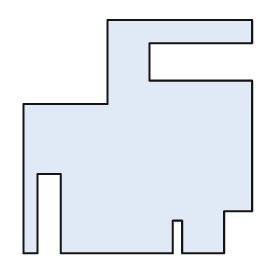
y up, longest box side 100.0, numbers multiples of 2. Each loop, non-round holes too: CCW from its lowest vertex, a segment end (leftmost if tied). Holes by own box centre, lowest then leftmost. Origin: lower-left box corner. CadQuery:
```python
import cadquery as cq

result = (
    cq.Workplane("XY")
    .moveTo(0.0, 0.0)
    .lineTo(6.0, 0.0)
    .lineTo(6.0, 34.0)
    .lineTo(16.0, 34.0)
    .lineTo(16.0, 0.0)
    .lineTo(64.0, 0.0)
    .lineTo(64.0, 14.0)
    .lineTo(68.0, 14.0)
    .lineTo(68.0, 0.0)
    .lineTo(86.0, 0.0)
    .lineTo(86.0, 18.0)
    .lineTo(98.0, 18.0)
    .lineTo(98.0, 74.0)
    .lineTo(54.0, 74.0)
    .lineTo(54.0, 90.0)
    .lineTo(98.0, 90.0)
    .lineTo(98.0, 100.0)
    .lineTo(36.0, 100.0)
    .lineTo(36.0, 64.0)
    .lineTo(0.0, 64.0)
    .close()
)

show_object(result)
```